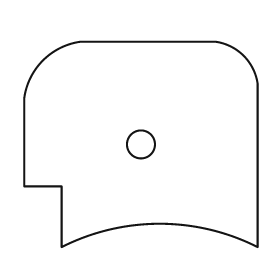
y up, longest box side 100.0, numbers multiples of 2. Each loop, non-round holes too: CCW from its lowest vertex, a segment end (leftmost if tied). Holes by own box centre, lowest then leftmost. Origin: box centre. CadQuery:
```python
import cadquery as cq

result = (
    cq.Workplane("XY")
    .moveTo(-34.0, -44.0)
    .threePointArc((8.0, -34.0), (50.0, -44.0))
    .lineTo(50.0, 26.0)
    .threePointArc((44.0, 38.0), (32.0, 44.0))
    .lineTo(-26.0, 44.0)
    .threePointArc((-42.0, 36.0), (-50.0, 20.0))
    .lineTo(-50.0, -18.0)
    .lineTo(-34.0, -18.0)
    .close()
    .moveTo(0.0, 0.0)
    .circle(6.0)
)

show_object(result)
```